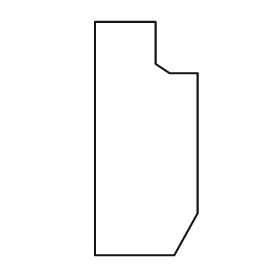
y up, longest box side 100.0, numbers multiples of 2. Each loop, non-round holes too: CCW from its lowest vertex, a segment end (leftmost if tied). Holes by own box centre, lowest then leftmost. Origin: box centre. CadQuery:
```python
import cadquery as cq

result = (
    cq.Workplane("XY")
    .moveTo(-22.0, -50.0)
    .lineTo(12.0, -50.0)
    .lineTo(22.0, -32.0)
    .lineTo(22.0, 28.0)
    .lineTo(10.0, 28.0)
    .lineTo(4.0, 32.0)
    .lineTo(4.0, 50.0)
    .lineTo(-22.0, 50.0)
    .close()
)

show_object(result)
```